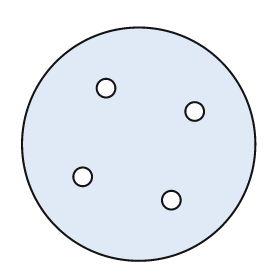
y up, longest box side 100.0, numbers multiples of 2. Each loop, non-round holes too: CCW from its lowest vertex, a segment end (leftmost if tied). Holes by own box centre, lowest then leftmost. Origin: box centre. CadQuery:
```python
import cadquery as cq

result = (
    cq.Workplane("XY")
    .moveTo(0.0, 0.0)
    .circle(50.0)
    .moveTo(14.0, -24.0)
    .circle(4.0)
    .moveTo(-24.0, -14.0)
    .circle(4.0)
    .moveTo(24.0, 14.0)
    .circle(4.0)
    .moveTo(-14.0, 24.0)
    .circle(4.0)
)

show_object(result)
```